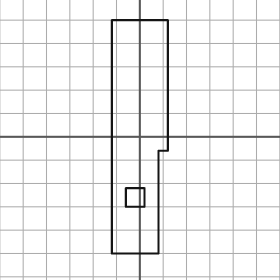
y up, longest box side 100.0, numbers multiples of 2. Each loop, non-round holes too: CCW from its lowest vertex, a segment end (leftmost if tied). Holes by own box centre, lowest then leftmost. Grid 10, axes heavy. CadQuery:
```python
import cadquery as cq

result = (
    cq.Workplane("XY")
    .moveTo(-12.0, -50.0)
    .lineTo(8.0, -50.0)
    .lineTo(8.0, -6.0)
    .lineTo(12.0, -6.0)
    .lineTo(12.0, 50.0)
    .lineTo(-12.0, 50.0)
    .close()
    .moveTo(-6.0, -30.0)
    .lineTo(2.0, -30.0)
    .lineTo(2.0, -22.0)
    .lineTo(-6.0, -22.0)
    .close()
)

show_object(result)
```